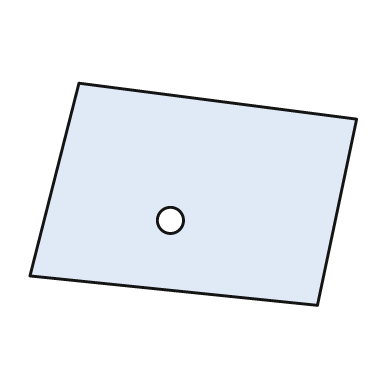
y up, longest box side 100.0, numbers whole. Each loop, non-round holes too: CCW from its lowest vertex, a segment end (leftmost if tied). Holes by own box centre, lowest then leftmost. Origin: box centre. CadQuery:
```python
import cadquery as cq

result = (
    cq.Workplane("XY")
    .moveTo(38.0, -34.0)
    .lineTo(50.0, 23.0)
    .lineTo(-35.0, 34.0)
    .lineTo(-50.0, -25.0)
    .close()
    .moveTo(-7.0, -8.0)
    .circle(4.0)
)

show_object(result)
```